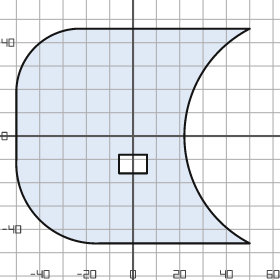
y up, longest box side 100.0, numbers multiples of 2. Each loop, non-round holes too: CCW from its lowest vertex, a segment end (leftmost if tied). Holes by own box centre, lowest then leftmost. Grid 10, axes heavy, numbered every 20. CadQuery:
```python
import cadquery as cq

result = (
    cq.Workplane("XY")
    .moveTo(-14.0, -46.0)
    .lineTo(50.0, -46.0)
    .threePointArc((22.0, 0.0), (50.0, 46.0))
    .lineTo(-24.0, 46.0)
    .threePointArc((-42.0, 38.0), (-50.0, 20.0))
    .lineTo(-50.0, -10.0)
    .threePointArc((-40.0, -36.0), (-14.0, -46.0))
    .close()
    .moveTo(-6.0, -16.0)
    .lineTo(6.0, -16.0)
    .lineTo(6.0, -8.0)
    .lineTo(-6.0, -8.0)
    .close()
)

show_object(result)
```